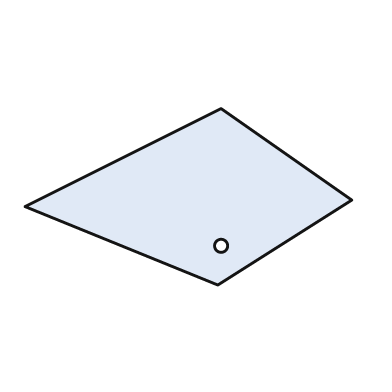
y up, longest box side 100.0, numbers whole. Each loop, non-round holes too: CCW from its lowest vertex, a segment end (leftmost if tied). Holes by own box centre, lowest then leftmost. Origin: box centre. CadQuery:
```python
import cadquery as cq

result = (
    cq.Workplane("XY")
    .moveTo(9.0, -27.0)
    .lineTo(50.0, -1.0)
    .lineTo(10.0, 27.0)
    .lineTo(-50.0, -3.0)
    .close()
    .moveTo(10.0, -15.0)
    .circle(2.0)
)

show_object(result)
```